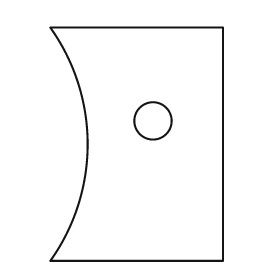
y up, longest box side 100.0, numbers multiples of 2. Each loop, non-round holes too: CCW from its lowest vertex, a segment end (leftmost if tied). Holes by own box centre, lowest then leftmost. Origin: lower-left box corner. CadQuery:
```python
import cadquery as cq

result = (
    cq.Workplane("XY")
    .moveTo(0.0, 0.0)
    .lineTo(74.0, 0.0)
    .lineTo(74.0, 100.0)
    .lineTo(0.0, 100.0)
    .threePointArc((16.0, 50.0), (0.0, 0.0))
    .close()
    .moveTo(44.0, 60.0)
    .circle(8.0)
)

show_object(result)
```